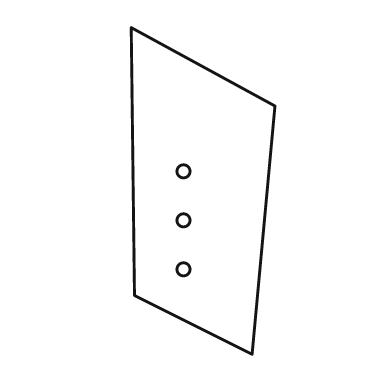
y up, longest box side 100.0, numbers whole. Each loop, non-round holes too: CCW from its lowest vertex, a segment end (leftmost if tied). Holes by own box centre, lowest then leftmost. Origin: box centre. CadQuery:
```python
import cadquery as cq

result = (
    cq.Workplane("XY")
    .moveTo(15.0, -50.0)
    .lineTo(22.0, 26.0)
    .lineTo(-22.0, 50.0)
    .lineTo(-21.0, -32.0)
    .close()
    .moveTo(-6.0, -24.0)
    .circle(2.0)
    .moveTo(-6.0, -9.0)
    .circle(2.0)
    .moveTo(-6.0, 6.0)
    .circle(2.0)
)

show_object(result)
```